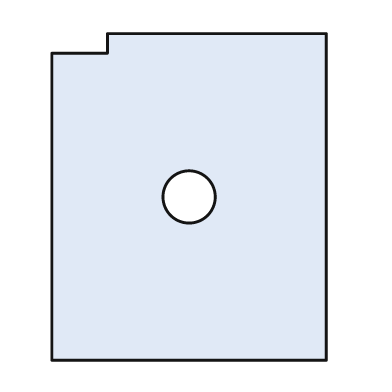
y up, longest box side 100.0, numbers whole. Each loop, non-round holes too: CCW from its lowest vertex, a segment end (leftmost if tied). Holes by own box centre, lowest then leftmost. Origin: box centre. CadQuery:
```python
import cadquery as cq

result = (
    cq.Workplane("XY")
    .moveTo(-42.0, -50.0)
    .lineTo(42.0, -50.0)
    .lineTo(42.0, 50.0)
    .lineTo(-25.0, 50.0)
    .lineTo(-25.0, 44.0)
    .lineTo(-42.0, 44.0)
    .close()
    .moveTo(0.0, 0.0)
    .circle(8.0)
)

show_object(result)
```